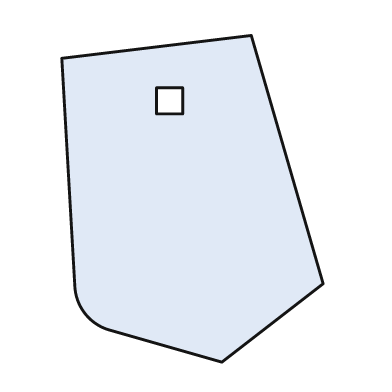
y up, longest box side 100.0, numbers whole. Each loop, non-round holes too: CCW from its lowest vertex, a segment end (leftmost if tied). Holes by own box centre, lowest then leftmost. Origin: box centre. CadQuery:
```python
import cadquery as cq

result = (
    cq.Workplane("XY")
    .moveTo(9.0, -50.0)
    .lineTo(40.0, -26.0)
    .lineTo(18.0, 50.0)
    .lineTo(-40.0, 43.0)
    .lineTo(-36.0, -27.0)
    .threePointArc((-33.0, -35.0), (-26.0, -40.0))
    .close()
    .moveTo(-11.0, 26.0)
    .lineTo(-3.0, 26.0)
    .lineTo(-3.0, 34.0)
    .lineTo(-11.0, 34.0)
    .close()
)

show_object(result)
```